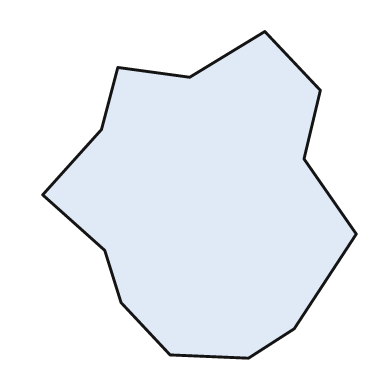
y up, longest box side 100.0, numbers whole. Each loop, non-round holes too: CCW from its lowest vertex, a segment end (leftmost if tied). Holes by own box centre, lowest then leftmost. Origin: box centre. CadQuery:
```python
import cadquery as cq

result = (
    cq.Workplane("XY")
    .moveTo(15.0, -50.0)
    .lineTo(29.0, -41.0)
    .lineTo(48.0, -12.0)
    .lineTo(32.0, 11.0)
    .lineTo(37.0, 32.0)
    .lineTo(20.0, 50.0)
    .lineTo(-3.0, 36.0)
    .lineTo(-25.0, 39.0)
    .lineTo(-30.0, 20.0)
    .lineTo(-48.0, 0.0)
    .lineTo(-29.0, -17.0)
    .lineTo(-24.0, -33.0)
    .lineTo(-9.0, -49.0)
    .close()
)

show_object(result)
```